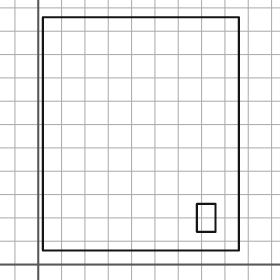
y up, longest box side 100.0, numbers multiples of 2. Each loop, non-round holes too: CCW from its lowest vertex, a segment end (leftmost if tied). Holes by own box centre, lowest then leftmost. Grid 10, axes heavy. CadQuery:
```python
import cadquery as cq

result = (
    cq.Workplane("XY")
    .moveTo(2.0, 6.0)
    .lineTo(86.0, 6.0)
    .lineTo(86.0, 106.0)
    .lineTo(2.0, 106.0)
    .close()
    .moveTo(68.0, 14.0)
    .lineTo(76.0, 14.0)
    .lineTo(76.0, 26.0)
    .lineTo(68.0, 26.0)
    .close()
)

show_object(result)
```